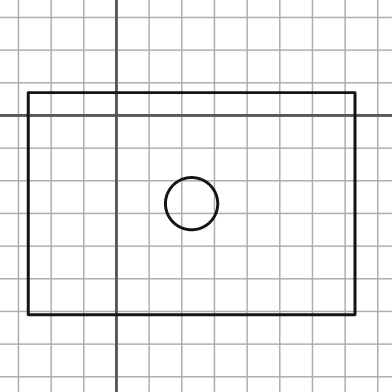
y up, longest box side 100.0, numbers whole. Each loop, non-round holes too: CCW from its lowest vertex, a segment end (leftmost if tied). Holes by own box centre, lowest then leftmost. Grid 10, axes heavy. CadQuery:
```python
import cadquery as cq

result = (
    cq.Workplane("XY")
    .moveTo(-27.0, -61.0)
    .lineTo(73.0, -61.0)
    .lineTo(73.0, 7.0)
    .lineTo(-27.0, 7.0)
    .close()
    .moveTo(23.0, -27.0)
    .circle(8.0)
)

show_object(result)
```